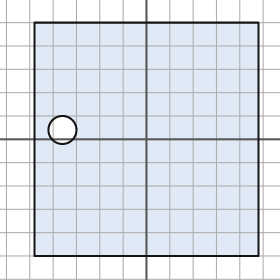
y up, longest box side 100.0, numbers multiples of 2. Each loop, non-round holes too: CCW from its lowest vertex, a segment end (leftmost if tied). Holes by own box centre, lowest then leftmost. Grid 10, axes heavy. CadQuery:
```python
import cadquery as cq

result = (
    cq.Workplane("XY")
    .moveTo(-48.0, -50.0)
    .lineTo(48.0, -50.0)
    .lineTo(48.0, 50.0)
    .lineTo(-48.0, 50.0)
    .close()
    .moveTo(-36.0, 4.0)
    .circle(6.0)
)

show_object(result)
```